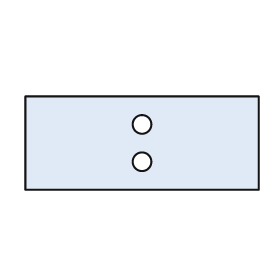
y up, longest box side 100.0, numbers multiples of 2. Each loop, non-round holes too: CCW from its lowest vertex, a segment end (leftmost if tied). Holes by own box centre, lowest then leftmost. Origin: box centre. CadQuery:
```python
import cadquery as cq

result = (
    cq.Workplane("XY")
    .moveTo(-50.0, -20.0)
    .lineTo(50.0, -20.0)
    .lineTo(50.0, 20.0)
    .lineTo(-50.0, 20.0)
    .close()
    .moveTo(0.0, -8.0)
    .circle(4.0)
    .moveTo(0.0, 8.0)
    .circle(4.0)
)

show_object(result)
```